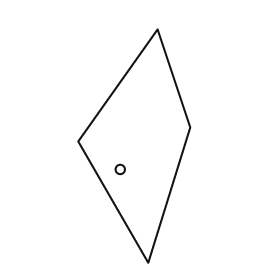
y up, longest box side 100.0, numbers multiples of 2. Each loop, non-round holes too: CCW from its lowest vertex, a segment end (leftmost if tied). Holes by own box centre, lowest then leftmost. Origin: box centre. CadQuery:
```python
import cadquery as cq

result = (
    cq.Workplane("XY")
    .moveTo(6.0, -50.0)
    .lineTo(24.0, 8.0)
    .lineTo(10.0, 50.0)
    .lineTo(-24.0, 2.0)
    .close()
    .moveTo(-6.0, -10.0)
    .circle(2.0)
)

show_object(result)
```